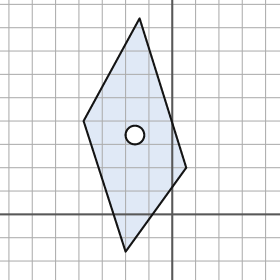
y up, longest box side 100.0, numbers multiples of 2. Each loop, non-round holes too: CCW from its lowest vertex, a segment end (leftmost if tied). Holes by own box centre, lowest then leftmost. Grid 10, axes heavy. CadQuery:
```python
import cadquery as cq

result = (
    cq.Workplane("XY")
    .moveTo(-20.0, -16.0)
    .lineTo(6.0, 20.0)
    .lineTo(-14.0, 84.0)
    .lineTo(-38.0, 40.0)
    .close()
    .moveTo(-16.0, 34.0)
    .circle(4.0)
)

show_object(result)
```